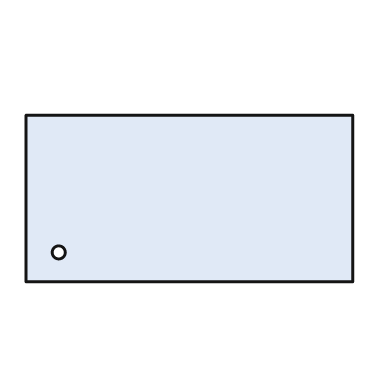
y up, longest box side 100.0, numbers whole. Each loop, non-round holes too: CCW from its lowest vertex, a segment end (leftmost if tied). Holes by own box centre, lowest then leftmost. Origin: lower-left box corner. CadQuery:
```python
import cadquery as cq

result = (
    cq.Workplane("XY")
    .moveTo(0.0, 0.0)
    .lineTo(100.0, 0.0)
    .lineTo(100.0, 51.0)
    .lineTo(0.0, 51.0)
    .close()
    .moveTo(10.0, 9.0)
    .circle(2.0)
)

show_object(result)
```